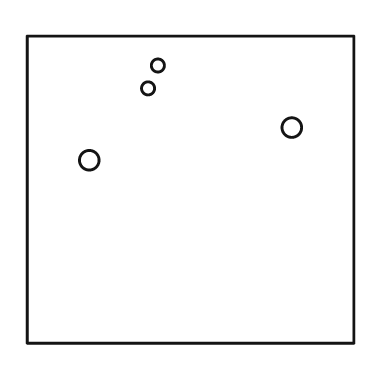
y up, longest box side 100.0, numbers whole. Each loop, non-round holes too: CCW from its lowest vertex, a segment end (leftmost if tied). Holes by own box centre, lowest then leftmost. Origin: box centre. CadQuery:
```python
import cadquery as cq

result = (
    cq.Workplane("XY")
    .moveTo(-50.0, -47.0)
    .lineTo(50.0, -47.0)
    .lineTo(50.0, 47.0)
    .lineTo(-50.0, 47.0)
    .close()
    .moveTo(-31.0, 9.0)
    .circle(3.0)
    .moveTo(31.0, 19.0)
    .circle(3.0)
    .moveTo(-13.0, 31.0)
    .circle(2.0)
    .moveTo(-10.0, 38.0)
    .circle(2.0)
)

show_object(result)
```